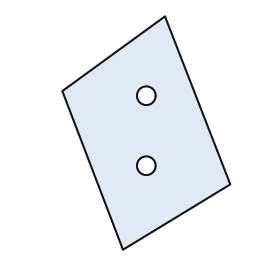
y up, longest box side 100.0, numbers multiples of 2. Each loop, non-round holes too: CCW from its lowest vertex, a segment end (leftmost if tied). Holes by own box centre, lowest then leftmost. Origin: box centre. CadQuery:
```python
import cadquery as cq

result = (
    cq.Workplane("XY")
    .moveTo(-10.0, -50.0)
    .lineTo(36.0, -22.0)
    .lineTo(8.0, 50.0)
    .lineTo(-36.0, 18.0)
    .close()
    .moveTo(0.0, -14.0)
    .circle(4.0)
    .moveTo(0.0, 16.0)
    .circle(4.0)
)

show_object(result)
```